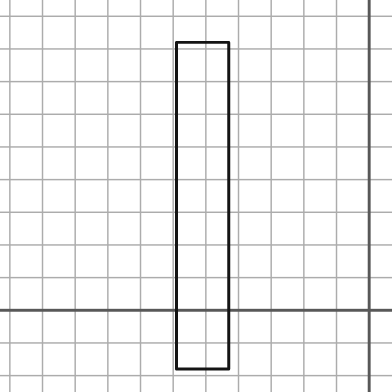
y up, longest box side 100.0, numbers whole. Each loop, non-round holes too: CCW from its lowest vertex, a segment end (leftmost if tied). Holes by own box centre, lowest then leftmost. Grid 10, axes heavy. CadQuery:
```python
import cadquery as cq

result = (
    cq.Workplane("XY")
    .moveTo(-59.0, -18.0)
    .lineTo(-43.0, -18.0)
    .lineTo(-43.0, 82.0)
    .lineTo(-59.0, 82.0)
    .close()
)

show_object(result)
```